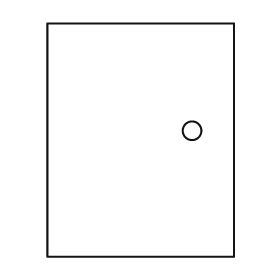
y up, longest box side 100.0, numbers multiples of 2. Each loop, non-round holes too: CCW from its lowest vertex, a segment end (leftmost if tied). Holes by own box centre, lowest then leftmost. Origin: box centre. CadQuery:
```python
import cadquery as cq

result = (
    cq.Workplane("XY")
    .moveTo(-40.0, -50.0)
    .lineTo(40.0, -50.0)
    .lineTo(40.0, 50.0)
    .lineTo(-40.0, 50.0)
    .close()
    .moveTo(22.0, 4.0)
    .circle(4.0)
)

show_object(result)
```